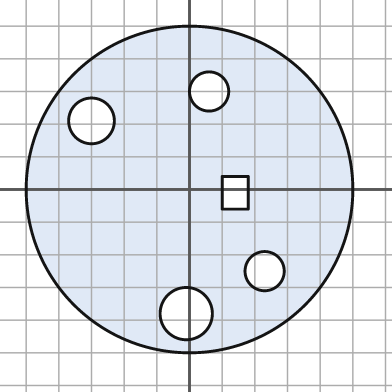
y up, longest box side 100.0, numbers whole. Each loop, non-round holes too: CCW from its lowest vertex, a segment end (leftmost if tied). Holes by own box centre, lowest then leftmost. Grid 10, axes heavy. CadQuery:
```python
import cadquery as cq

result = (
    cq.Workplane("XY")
    .moveTo(0.0, 0.0)
    .circle(50.0)
    .moveTo(-1.0, -38.0)
    .circle(8.0)
    .moveTo(23.0, -25.0)
    .circle(6.0)
    .moveTo(10.0, -6.0)
    .lineTo(18.0, -6.0)
    .lineTo(18.0, 4.0)
    .lineTo(10.0, 4.0)
    .close()
    .moveTo(-30.0, 21.0)
    .circle(7.0)
    .moveTo(6.0, 30.0)
    .circle(6.0)
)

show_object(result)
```